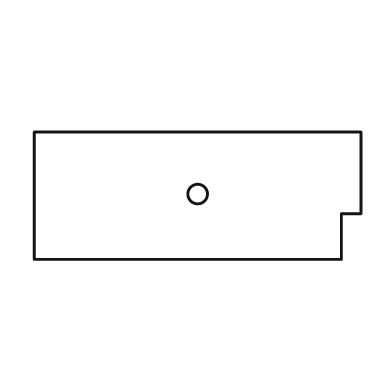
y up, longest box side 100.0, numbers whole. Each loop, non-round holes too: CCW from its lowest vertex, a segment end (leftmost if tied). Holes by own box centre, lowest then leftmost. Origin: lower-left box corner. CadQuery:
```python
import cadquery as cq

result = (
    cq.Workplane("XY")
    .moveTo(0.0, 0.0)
    .lineTo(94.0, 0.0)
    .lineTo(94.0, 14.0)
    .lineTo(100.0, 14.0)
    .lineTo(100.0, 39.0)
    .lineTo(0.0, 39.0)
    .close()
    .moveTo(50.0, 20.0)
    .circle(3.0)
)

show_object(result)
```